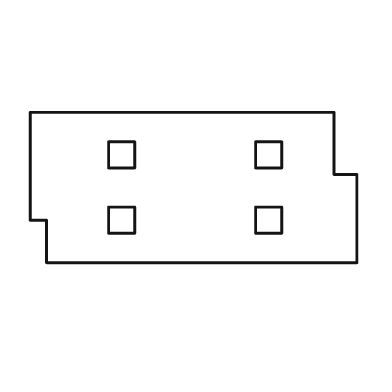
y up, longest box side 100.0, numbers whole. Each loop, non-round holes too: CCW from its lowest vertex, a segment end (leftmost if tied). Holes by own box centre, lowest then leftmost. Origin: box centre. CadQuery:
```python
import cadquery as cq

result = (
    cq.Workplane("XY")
    .moveTo(-45.0, -23.0)
    .lineTo(50.0, -23.0)
    .lineTo(50.0, 4.0)
    .lineTo(43.0, 4.0)
    .lineTo(43.0, 23.0)
    .lineTo(-50.0, 23.0)
    .lineTo(-50.0, -10.0)
    .lineTo(-45.0, -10.0)
    .close()
    .moveTo(-26.0, -14.0)
    .lineTo(-18.0, -14.0)
    .lineTo(-18.0, -6.0)
    .lineTo(-26.0, -6.0)
    .close()
    .moveTo(19.0, -14.0)
    .lineTo(27.0, -14.0)
    .lineTo(27.0, -6.0)
    .lineTo(19.0, -6.0)
    .close()
    .moveTo(-26.0, 6.0)
    .lineTo(-18.0, 6.0)
    .lineTo(-18.0, 14.0)
    .lineTo(-26.0, 14.0)
    .close()
    .moveTo(19.0, 6.0)
    .lineTo(27.0, 6.0)
    .lineTo(27.0, 14.0)
    .lineTo(19.0, 14.0)
    .close()
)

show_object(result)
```